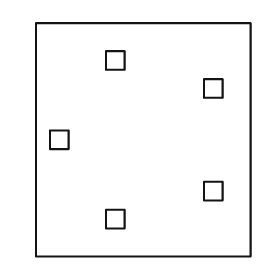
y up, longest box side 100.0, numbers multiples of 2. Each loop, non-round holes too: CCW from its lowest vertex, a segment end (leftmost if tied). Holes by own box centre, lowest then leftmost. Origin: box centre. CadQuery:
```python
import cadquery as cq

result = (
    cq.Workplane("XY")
    .moveTo(-46.0, -50.0)
    .lineTo(46.0, -50.0)
    .lineTo(46.0, 50.0)
    .lineTo(-46.0, 50.0)
    .close()
    .moveTo(-16.0, -38.0)
    .lineTo(-8.0, -38.0)
    .lineTo(-8.0, -30.0)
    .lineTo(-16.0, -30.0)
    .close()
    .moveTo(26.0, -26.0)
    .lineTo(34.0, -26.0)
    .lineTo(34.0, -18.0)
    .lineTo(26.0, -18.0)
    .close()
    .moveTo(-40.0, -4.0)
    .lineTo(-32.0, -4.0)
    .lineTo(-32.0, 4.0)
    .lineTo(-40.0, 4.0)
    .close()
    .moveTo(26.0, 18.0)
    .lineTo(34.0, 18.0)
    .lineTo(34.0, 26.0)
    .lineTo(26.0, 26.0)
    .close()
    .moveTo(-16.0, 30.0)
    .lineTo(-8.0, 30.0)
    .lineTo(-8.0, 38.0)
    .lineTo(-16.0, 38.0)
    .close()
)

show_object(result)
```